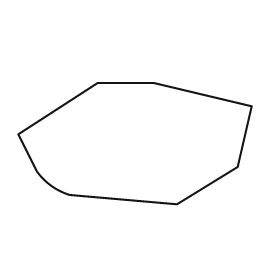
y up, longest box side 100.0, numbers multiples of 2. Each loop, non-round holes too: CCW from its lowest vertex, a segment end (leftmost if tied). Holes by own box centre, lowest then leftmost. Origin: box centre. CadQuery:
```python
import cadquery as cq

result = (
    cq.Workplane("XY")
    .moveTo(18.0, -26.0)
    .lineTo(44.0, -10.0)
    .lineTo(50.0, 16.0)
    .lineTo(8.0, 26.0)
    .lineTo(-16.0, 26.0)
    .lineTo(-50.0, 4.0)
    .lineTo(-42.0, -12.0)
    .threePointArc((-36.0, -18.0), (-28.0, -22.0))
    .close()
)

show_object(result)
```